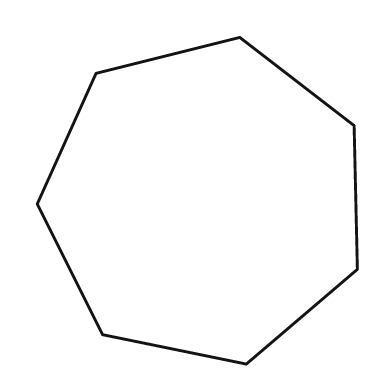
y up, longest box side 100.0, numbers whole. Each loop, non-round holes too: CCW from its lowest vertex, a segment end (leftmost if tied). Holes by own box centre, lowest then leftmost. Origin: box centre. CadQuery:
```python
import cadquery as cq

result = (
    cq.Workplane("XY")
    .moveTo(15.0, -50.0)
    .lineTo(49.0, -21.0)
    .lineTo(48.0, 23.0)
    .lineTo(13.0, 50.0)
    .lineTo(-31.0, 39.0)
    .lineTo(-49.0, -1.0)
    .lineTo(-29.0, -41.0)
    .close()
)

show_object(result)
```